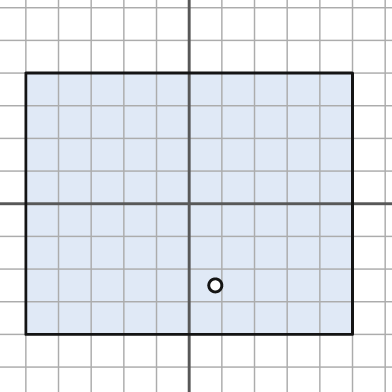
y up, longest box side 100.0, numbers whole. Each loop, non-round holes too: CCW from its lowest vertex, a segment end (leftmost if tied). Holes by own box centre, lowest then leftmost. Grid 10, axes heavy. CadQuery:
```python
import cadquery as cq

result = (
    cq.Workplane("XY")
    .moveTo(-50.0, -40.0)
    .lineTo(50.0, -40.0)
    .lineTo(50.0, 40.0)
    .lineTo(-50.0, 40.0)
    .close()
    .moveTo(8.0, -25.0)
    .circle(2.0)
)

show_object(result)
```